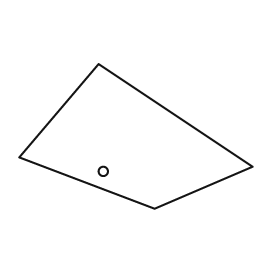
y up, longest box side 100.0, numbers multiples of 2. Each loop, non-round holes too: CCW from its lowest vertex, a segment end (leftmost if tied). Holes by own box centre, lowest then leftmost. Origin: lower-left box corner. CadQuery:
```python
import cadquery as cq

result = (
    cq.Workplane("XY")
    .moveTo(58.0, 0.0)
    .lineTo(100.0, 18.0)
    .lineTo(34.0, 62.0)
    .lineTo(0.0, 22.0)
    .close()
    .moveTo(36.0, 16.0)
    .circle(2.0)
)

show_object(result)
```